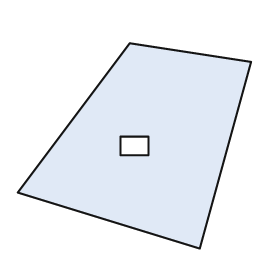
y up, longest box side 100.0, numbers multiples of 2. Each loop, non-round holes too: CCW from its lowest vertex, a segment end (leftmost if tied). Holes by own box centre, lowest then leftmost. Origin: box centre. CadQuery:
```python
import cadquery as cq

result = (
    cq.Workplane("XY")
    .moveTo(28.0, -44.0)
    .lineTo(50.0, 36.0)
    .lineTo(-2.0, 44.0)
    .lineTo(-50.0, -20.0)
    .close()
    .moveTo(-6.0, -4.0)
    .lineTo(6.0, -4.0)
    .lineTo(6.0, 4.0)
    .lineTo(-6.0, 4.0)
    .close()
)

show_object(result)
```